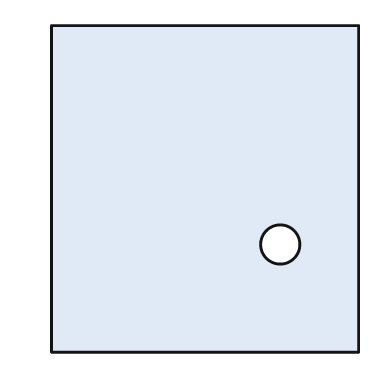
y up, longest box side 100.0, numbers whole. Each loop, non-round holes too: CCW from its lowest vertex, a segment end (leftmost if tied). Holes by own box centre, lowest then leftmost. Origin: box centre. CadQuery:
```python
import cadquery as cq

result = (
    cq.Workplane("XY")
    .moveTo(-47.0, -50.0)
    .lineTo(47.0, -50.0)
    .lineTo(47.0, 50.0)
    .lineTo(-47.0, 50.0)
    .close()
    .moveTo(23.0, -17.0)
    .circle(6.0)
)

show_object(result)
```